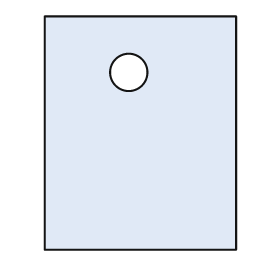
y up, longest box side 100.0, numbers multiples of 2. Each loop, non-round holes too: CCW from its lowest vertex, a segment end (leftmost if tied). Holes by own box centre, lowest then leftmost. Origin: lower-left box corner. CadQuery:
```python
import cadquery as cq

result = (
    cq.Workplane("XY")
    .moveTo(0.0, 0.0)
    .lineTo(82.0, 0.0)
    .lineTo(82.0, 100.0)
    .lineTo(0.0, 100.0)
    .close()
    .moveTo(36.0, 76.0)
    .circle(8.0)
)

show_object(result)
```